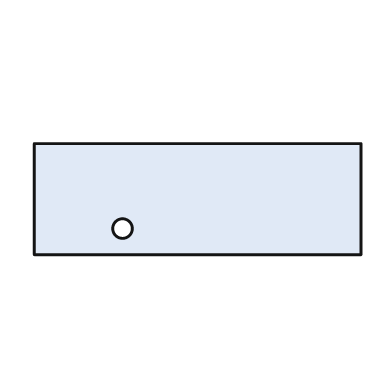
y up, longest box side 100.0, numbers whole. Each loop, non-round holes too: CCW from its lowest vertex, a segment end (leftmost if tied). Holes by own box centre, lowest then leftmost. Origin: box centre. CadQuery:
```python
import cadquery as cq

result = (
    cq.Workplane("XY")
    .moveTo(-50.0, -17.0)
    .lineTo(50.0, -17.0)
    .lineTo(50.0, 17.0)
    .lineTo(-50.0, 17.0)
    .close()
    .moveTo(-23.0, -9.0)
    .circle(3.0)
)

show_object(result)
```